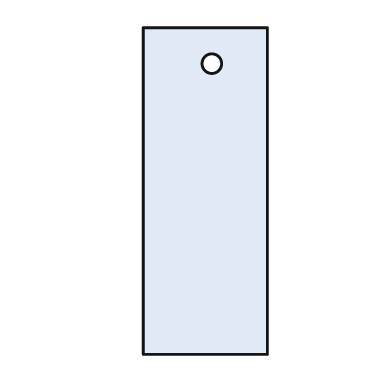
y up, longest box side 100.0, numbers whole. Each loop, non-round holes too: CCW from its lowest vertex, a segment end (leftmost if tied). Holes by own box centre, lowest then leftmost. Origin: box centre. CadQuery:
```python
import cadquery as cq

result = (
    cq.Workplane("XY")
    .moveTo(-19.0, -50.0)
    .lineTo(19.0, -50.0)
    .lineTo(19.0, 50.0)
    .lineTo(-19.0, 50.0)
    .close()
    .moveTo(2.0, 39.0)
    .circle(3.0)
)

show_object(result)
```